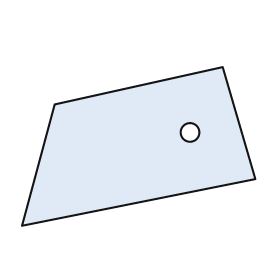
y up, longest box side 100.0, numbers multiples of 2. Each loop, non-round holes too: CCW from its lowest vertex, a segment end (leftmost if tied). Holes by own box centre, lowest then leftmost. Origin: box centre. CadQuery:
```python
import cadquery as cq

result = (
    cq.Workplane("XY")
    .moveTo(-50.0, -34.0)
    .lineTo(50.0, -14.0)
    .lineTo(36.0, 34.0)
    .lineTo(-36.0, 18.0)
    .close()
    .moveTo(22.0, 6.0)
    .circle(4.0)
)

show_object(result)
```